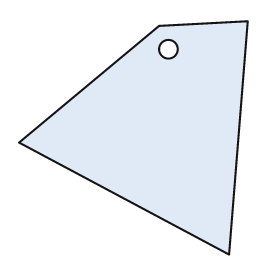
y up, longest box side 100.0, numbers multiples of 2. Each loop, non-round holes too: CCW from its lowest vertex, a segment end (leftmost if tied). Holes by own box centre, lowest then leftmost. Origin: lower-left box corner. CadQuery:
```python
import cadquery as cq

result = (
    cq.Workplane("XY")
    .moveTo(90.0, 0.0)
    .lineTo(98.0, 100.0)
    .lineTo(60.0, 98.0)
    .lineTo(0.0, 48.0)
    .close()
    .moveTo(64.0, 88.0)
    .circle(4.0)
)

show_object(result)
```